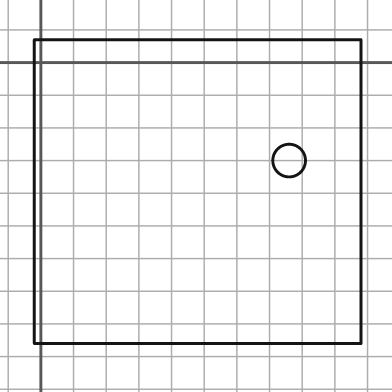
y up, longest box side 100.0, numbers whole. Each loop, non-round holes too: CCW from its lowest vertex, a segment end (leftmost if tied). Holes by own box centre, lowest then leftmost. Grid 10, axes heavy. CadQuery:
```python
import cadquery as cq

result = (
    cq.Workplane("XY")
    .moveTo(-2.0, -86.0)
    .lineTo(98.0, -86.0)
    .lineTo(98.0, 7.0)
    .lineTo(-2.0, 7.0)
    .close()
    .moveTo(76.0, -30.0)
    .circle(5.0)
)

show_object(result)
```